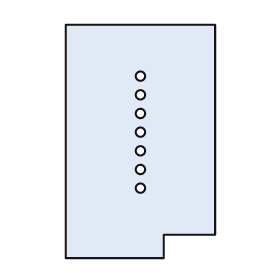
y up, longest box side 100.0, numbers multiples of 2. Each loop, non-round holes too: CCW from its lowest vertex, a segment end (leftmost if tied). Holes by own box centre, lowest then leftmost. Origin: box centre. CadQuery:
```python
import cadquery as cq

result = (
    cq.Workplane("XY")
    .moveTo(-32.0, -50.0)
    .lineTo(10.0, -50.0)
    .lineTo(10.0, -40.0)
    .lineTo(32.0, -40.0)
    .lineTo(32.0, 50.0)
    .lineTo(-32.0, 50.0)
    .close()
    .moveTo(0.0, -20.0)
    .circle(2.0)
    .moveTo(0.0, -12.0)
    .circle(2.0)
    .moveTo(0.0, -4.0)
    .circle(2.0)
    .moveTo(0.0, 4.0)
    .circle(2.0)
    .moveTo(0.0, 12.0)
    .circle(2.0)
    .moveTo(0.0, 20.0)
    .circle(2.0)
    .moveTo(0.0, 28.0)
    .circle(2.0)
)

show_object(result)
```